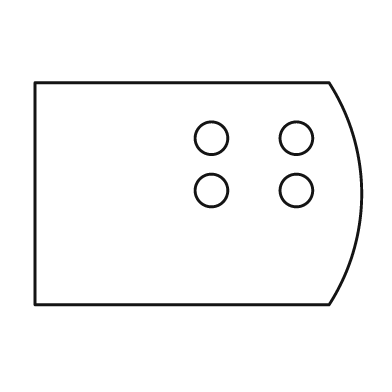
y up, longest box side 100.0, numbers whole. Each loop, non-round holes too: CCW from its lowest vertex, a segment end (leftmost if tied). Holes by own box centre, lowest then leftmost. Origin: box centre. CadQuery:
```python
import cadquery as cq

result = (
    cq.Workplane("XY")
    .moveTo(-50.0, -34.0)
    .lineTo(40.0, -34.0)
    .threePointArc((50.0, 0.0), (40.0, 34.0))
    .lineTo(-50.0, 34.0)
    .close()
    .moveTo(4.0, 1.0)
    .circle(5.0)
    .moveTo(30.0, 1.0)
    .circle(5.0)
    .moveTo(4.0, 17.0)
    .circle(5.0)
    .moveTo(30.0, 17.0)
    .circle(5.0)
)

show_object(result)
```